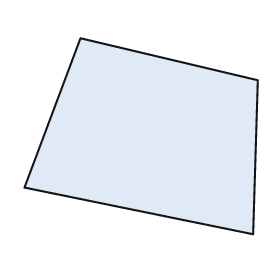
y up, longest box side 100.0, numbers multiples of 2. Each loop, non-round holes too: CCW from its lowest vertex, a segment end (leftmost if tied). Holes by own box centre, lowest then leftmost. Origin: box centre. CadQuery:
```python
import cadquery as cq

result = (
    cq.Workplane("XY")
    .moveTo(48.0, -42.0)
    .lineTo(50.0, 24.0)
    .lineTo(-26.0, 42.0)
    .lineTo(-50.0, -22.0)
    .close()
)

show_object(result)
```